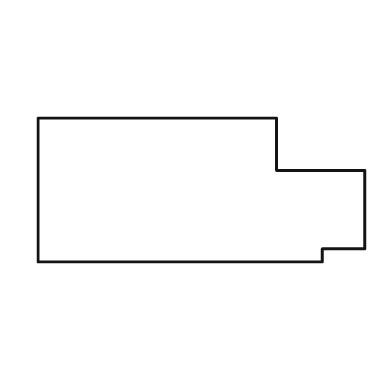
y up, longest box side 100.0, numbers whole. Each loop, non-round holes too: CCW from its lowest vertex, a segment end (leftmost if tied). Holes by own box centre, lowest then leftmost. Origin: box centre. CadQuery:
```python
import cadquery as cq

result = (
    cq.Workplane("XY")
    .moveTo(-50.0, -22.0)
    .lineTo(37.0, -22.0)
    .lineTo(37.0, -18.0)
    .lineTo(50.0, -18.0)
    .lineTo(50.0, 6.0)
    .lineTo(23.0, 6.0)
    .lineTo(23.0, 22.0)
    .lineTo(-50.0, 22.0)
    .close()
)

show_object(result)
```